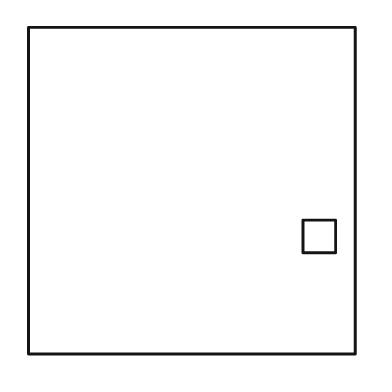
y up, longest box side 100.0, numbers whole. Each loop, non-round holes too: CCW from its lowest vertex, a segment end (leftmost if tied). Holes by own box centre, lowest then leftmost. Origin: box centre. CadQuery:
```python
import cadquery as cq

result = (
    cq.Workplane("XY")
    .moveTo(-50.0, -50.0)
    .lineTo(50.0, -50.0)
    .lineTo(50.0, 50.0)
    .lineTo(-50.0, 50.0)
    .close()
    .moveTo(34.0, -19.0)
    .lineTo(44.0, -19.0)
    .lineTo(44.0, -9.0)
    .lineTo(34.0, -9.0)
    .close()
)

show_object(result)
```